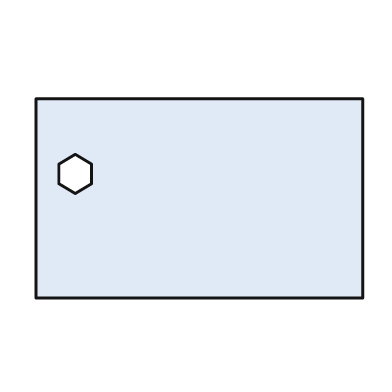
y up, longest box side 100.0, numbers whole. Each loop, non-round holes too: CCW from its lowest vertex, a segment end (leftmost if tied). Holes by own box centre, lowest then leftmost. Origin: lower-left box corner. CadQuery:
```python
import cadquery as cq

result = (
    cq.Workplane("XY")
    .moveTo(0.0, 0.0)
    .lineTo(100.0, 0.0)
    .lineTo(100.0, 61.0)
    .lineTo(0.0, 61.0)
    .close()
    .moveTo(12.0, 32.0)
    .lineTo(17.0, 35.0)
    .lineTo(17.0, 41.0)
    .lineTo(12.0, 44.0)
    .lineTo(7.0, 41.0)
    .lineTo(7.0, 35.0)
    .close()
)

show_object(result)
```